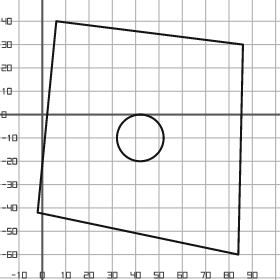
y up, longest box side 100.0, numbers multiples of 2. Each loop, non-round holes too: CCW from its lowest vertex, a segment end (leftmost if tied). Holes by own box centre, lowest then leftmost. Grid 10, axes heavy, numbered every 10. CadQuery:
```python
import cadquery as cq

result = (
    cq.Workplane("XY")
    .moveTo(84.0, -60.0)
    .lineTo(86.0, 30.0)
    .lineTo(6.0, 40.0)
    .lineTo(-2.0, -42.0)
    .close()
    .moveTo(42.0, -10.0)
    .circle(10.0)
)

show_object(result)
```